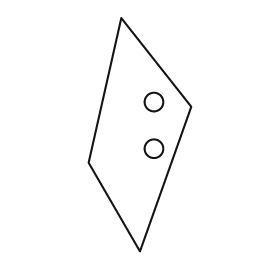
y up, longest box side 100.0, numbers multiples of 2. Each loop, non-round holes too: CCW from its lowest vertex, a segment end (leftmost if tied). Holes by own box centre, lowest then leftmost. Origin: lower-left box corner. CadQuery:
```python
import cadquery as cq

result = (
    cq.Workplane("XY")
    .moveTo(22.0, 0.0)
    .lineTo(44.0, 62.0)
    .lineTo(14.0, 100.0)
    .lineTo(0.0, 38.0)
    .close()
    .moveTo(28.0, 44.0)
    .circle(4.0)
    .moveTo(28.0, 64.0)
    .circle(4.0)
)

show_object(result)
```